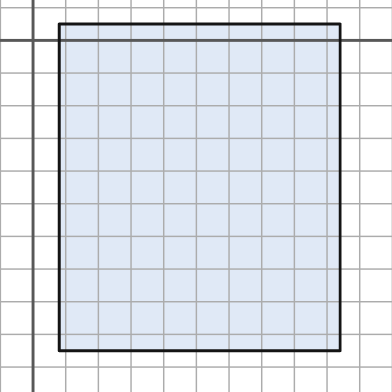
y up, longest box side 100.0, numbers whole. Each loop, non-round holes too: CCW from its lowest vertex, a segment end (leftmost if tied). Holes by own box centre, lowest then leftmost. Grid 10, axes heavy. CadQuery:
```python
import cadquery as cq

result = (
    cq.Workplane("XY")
    .moveTo(8.0, -95.0)
    .lineTo(94.0, -95.0)
    .lineTo(94.0, 5.0)
    .lineTo(8.0, 5.0)
    .close()
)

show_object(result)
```